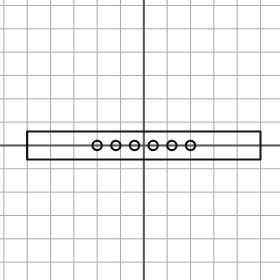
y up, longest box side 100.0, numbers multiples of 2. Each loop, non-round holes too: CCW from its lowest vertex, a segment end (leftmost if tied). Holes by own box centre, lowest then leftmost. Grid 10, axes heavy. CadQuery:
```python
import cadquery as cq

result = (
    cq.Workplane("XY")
    .moveTo(-50.0, -6.0)
    .lineTo(50.0, -6.0)
    .lineTo(50.0, 6.0)
    .lineTo(-50.0, 6.0)
    .close()
    .moveTo(-20.0, 0.0)
    .circle(2.0)
    .moveTo(-12.0, 0.0)
    .circle(2.0)
    .moveTo(-4.0, 0.0)
    .circle(2.0)
    .moveTo(4.0, 0.0)
    .circle(2.0)
    .moveTo(12.0, 0.0)
    .circle(2.0)
    .moveTo(20.0, 0.0)
    .circle(2.0)
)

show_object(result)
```